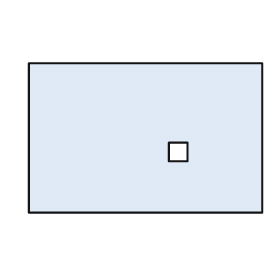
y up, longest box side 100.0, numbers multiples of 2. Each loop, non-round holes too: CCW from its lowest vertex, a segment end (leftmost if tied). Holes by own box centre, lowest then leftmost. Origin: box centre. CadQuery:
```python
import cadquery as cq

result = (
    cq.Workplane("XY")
    .moveTo(-50.0, -32.0)
    .lineTo(50.0, -32.0)
    .lineTo(50.0, 32.0)
    .lineTo(-50.0, 32.0)
    .close()
    .moveTo(10.0, -10.0)
    .lineTo(18.0, -10.0)
    .lineTo(18.0, -2.0)
    .lineTo(10.0, -2.0)
    .close()
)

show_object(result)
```